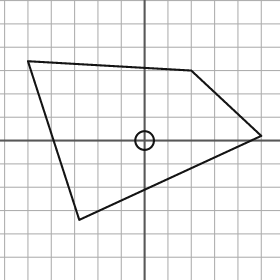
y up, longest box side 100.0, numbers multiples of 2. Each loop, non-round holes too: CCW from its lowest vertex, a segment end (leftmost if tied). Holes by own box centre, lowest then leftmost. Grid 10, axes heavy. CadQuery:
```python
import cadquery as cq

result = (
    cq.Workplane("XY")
    .moveTo(-28.0, -34.0)
    .lineTo(50.0, 2.0)
    .lineTo(20.0, 30.0)
    .lineTo(-50.0, 34.0)
    .close()
    .moveTo(0.0, 0.0)
    .circle(4.0)
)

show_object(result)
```